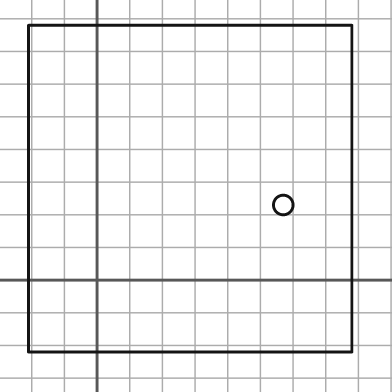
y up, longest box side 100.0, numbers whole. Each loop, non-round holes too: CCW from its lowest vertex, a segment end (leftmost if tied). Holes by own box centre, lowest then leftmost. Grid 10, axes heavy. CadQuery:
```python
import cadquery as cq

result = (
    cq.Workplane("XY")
    .moveTo(-21.0, -22.0)
    .lineTo(78.0, -22.0)
    .lineTo(78.0, 78.0)
    .lineTo(-21.0, 78.0)
    .close()
    .moveTo(57.0, 23.0)
    .circle(3.0)
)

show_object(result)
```